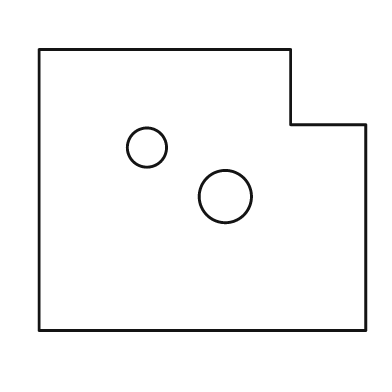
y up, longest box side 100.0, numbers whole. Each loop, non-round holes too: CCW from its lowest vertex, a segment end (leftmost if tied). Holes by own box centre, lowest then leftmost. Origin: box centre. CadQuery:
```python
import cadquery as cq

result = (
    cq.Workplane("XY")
    .moveTo(-50.0, -43.0)
    .lineTo(50.0, -43.0)
    .lineTo(50.0, 20.0)
    .lineTo(27.0, 20.0)
    .lineTo(27.0, 43.0)
    .lineTo(-50.0, 43.0)
    .close()
    .moveTo(7.0, -2.0)
    .circle(8.0)
    .moveTo(-17.0, 13.0)
    .circle(6.0)
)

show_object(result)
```